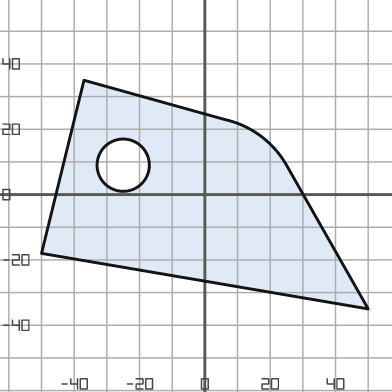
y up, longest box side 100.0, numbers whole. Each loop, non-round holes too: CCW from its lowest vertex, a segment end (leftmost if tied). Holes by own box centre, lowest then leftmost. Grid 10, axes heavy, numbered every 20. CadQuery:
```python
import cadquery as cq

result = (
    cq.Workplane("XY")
    .moveTo(50.0, -35.0)
    .lineTo(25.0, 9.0)
    .threePointArc((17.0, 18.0), (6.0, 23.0))
    .lineTo(-37.0, 35.0)
    .lineTo(-50.0, -18.0)
    .close()
    .moveTo(-25.0, 9.0)
    .circle(8.0)
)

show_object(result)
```